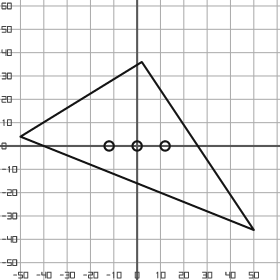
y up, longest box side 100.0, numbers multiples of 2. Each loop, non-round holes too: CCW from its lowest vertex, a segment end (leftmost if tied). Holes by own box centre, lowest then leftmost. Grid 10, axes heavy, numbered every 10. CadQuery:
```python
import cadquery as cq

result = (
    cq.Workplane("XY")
    .moveTo(50.0, -36.0)
    .lineTo(2.0, 36.0)
    .lineTo(-50.0, 4.0)
    .close()
    .moveTo(-12.0, 0.0)
    .circle(2.0)
    .moveTo(0.0, 0.0)
    .circle(2.0)
    .moveTo(12.0, 0.0)
    .circle(2.0)
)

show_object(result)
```